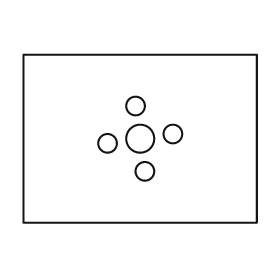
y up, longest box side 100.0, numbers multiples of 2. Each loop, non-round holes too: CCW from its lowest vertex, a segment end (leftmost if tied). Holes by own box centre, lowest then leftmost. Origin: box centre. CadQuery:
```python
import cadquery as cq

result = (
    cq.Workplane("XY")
    .moveTo(-50.0, -36.0)
    .lineTo(50.0, -36.0)
    .lineTo(50.0, 36.0)
    .lineTo(-50.0, 36.0)
    .close()
    .moveTo(2.0, -14.0)
    .circle(4.0)
    .moveTo(-14.0, -2.0)
    .circle(4.0)
    .moveTo(0.0, 0.0)
    .circle(6.0)
    .moveTo(14.0, 2.0)
    .circle(4.0)
    .moveTo(-2.0, 14.0)
    .circle(4.0)
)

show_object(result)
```